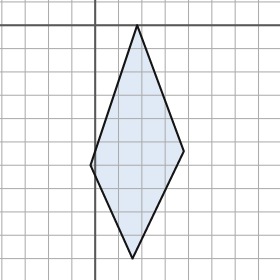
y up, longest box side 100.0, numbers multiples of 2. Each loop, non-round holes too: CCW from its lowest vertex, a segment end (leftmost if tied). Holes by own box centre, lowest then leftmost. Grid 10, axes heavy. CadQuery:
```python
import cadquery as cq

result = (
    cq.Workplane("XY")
    .moveTo(16.0, -100.0)
    .lineTo(38.0, -54.0)
    .lineTo(18.0, 0.0)
    .lineTo(-2.0, -60.0)
    .close()
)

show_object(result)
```